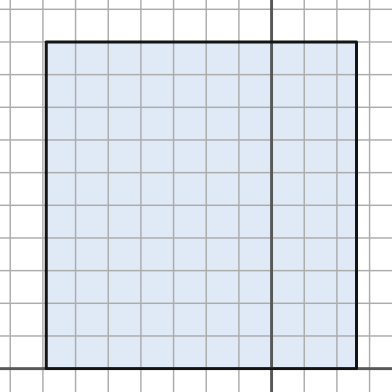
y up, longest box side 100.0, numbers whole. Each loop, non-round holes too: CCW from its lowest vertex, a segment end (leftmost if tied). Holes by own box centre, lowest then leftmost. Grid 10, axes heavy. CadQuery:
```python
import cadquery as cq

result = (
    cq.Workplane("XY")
    .moveTo(-69.0, 0.0)
    .lineTo(26.0, 0.0)
    .lineTo(26.0, 100.0)
    .lineTo(-69.0, 100.0)
    .close()
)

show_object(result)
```